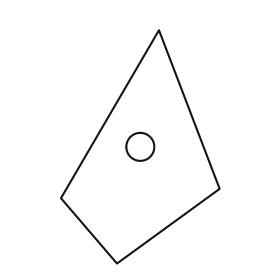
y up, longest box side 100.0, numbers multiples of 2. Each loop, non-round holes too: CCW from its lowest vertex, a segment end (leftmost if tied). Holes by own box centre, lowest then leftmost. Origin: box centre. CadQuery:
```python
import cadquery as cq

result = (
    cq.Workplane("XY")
    .moveTo(-10.0, -50.0)
    .lineTo(34.0, -18.0)
    .lineTo(8.0, 50.0)
    .lineTo(-34.0, -22.0)
    .close()
    .moveTo(0.0, 0.0)
    .circle(6.0)
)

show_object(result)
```